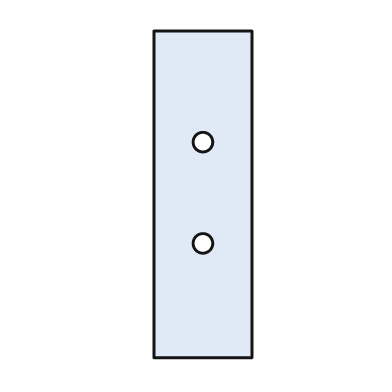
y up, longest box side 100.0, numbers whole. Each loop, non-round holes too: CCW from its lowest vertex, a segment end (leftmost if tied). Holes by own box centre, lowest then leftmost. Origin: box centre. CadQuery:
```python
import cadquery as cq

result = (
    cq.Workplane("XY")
    .moveTo(-15.0, -50.0)
    .lineTo(15.0, -50.0)
    .lineTo(15.0, 50.0)
    .lineTo(-15.0, 50.0)
    .close()
    .moveTo(0.0, -15.0)
    .circle(3.0)
    .moveTo(0.0, 16.0)
    .circle(3.0)
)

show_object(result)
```